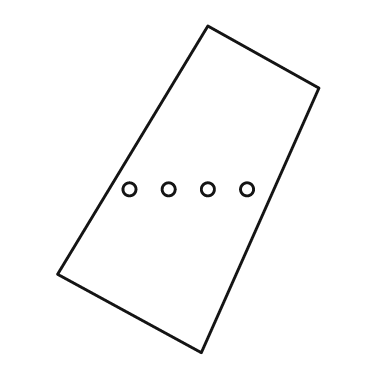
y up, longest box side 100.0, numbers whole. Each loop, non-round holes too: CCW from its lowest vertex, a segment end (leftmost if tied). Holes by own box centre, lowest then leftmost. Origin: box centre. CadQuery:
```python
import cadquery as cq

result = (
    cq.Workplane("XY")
    .moveTo(4.0, -50.0)
    .lineTo(40.0, 31.0)
    .lineTo(6.0, 50.0)
    .lineTo(-40.0, -26.0)
    .close()
    .moveTo(-18.0, 0.0)
    .circle(2.0)
    .moveTo(-6.0, 0.0)
    .circle(2.0)
    .moveTo(6.0, 0.0)
    .circle(2.0)
    .moveTo(18.0, 0.0)
    .circle(2.0)
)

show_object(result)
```